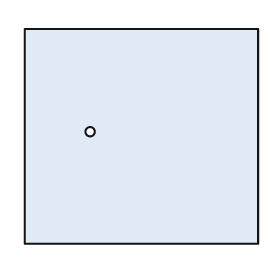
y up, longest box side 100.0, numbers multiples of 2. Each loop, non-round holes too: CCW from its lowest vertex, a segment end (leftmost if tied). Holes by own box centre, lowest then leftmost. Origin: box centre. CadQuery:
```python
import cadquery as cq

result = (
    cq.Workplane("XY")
    .moveTo(-50.0, -46.0)
    .lineTo(50.0, -46.0)
    .lineTo(50.0, 46.0)
    .lineTo(-50.0, 46.0)
    .close()
    .moveTo(-22.0, 2.0)
    .circle(2.0)
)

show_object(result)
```